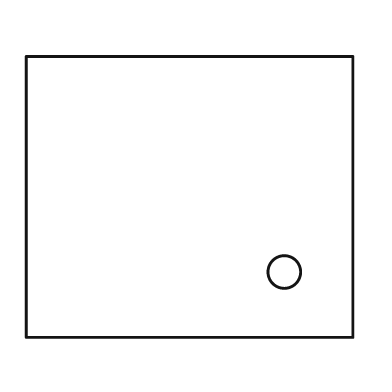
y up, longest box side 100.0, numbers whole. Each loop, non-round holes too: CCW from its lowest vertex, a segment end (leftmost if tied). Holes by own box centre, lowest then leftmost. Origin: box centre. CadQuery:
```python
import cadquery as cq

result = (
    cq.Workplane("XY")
    .moveTo(-50.0, -43.0)
    .lineTo(50.0, -43.0)
    .lineTo(50.0, 43.0)
    .lineTo(-50.0, 43.0)
    .close()
    .moveTo(29.0, -23.0)
    .circle(5.0)
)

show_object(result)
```